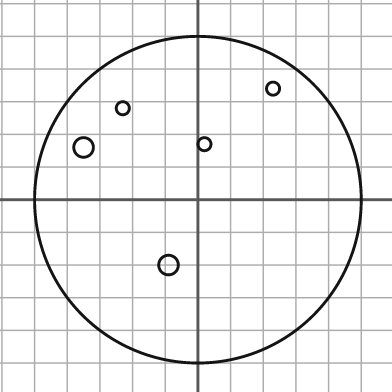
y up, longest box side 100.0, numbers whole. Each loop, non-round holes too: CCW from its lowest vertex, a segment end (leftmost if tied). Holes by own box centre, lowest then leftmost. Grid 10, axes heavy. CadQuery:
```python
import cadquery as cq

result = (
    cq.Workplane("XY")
    .moveTo(0.0, 0.0)
    .circle(50.0)
    .moveTo(-9.0, -20.0)
    .circle(3.0)
    .moveTo(-35.0, 16.0)
    .circle(3.0)
    .moveTo(2.0, 17.0)
    .circle(2.0)
    .moveTo(-23.0, 28.0)
    .circle(2.0)
    .moveTo(23.0, 34.0)
    .circle(2.0)
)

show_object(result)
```